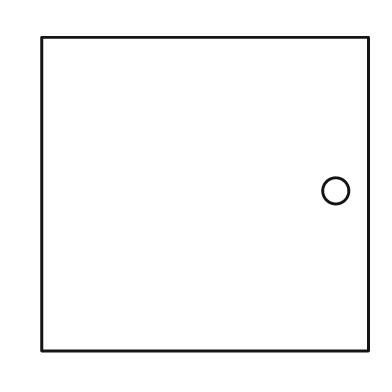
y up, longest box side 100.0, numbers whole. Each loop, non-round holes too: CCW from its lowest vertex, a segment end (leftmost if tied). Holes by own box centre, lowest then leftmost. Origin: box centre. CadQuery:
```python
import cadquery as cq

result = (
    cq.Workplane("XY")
    .moveTo(-50.0, -48.0)
    .lineTo(50.0, -48.0)
    .lineTo(50.0, 48.0)
    .lineTo(-50.0, 48.0)
    .close()
    .moveTo(40.0, 1.0)
    .circle(4.0)
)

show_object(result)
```